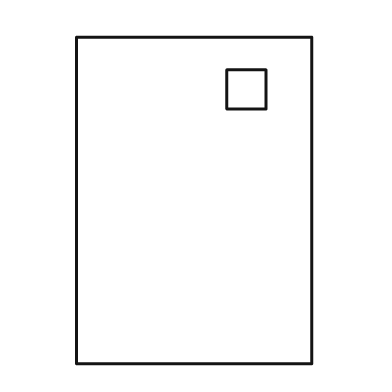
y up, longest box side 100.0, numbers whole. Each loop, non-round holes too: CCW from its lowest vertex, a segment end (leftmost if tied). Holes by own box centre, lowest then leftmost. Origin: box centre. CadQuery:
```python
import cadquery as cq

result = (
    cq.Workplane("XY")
    .moveTo(-36.0, -50.0)
    .lineTo(36.0, -50.0)
    .lineTo(36.0, 50.0)
    .lineTo(-36.0, 50.0)
    .close()
    .moveTo(10.0, 28.0)
    .lineTo(22.0, 28.0)
    .lineTo(22.0, 40.0)
    .lineTo(10.0, 40.0)
    .close()
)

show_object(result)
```